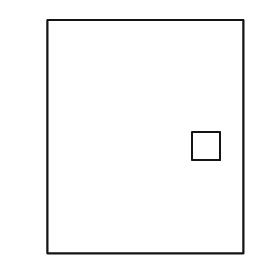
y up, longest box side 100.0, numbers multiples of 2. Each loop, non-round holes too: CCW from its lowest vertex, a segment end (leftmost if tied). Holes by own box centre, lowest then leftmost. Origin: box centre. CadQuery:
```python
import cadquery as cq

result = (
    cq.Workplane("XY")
    .moveTo(-42.0, -50.0)
    .lineTo(42.0, -50.0)
    .lineTo(42.0, 50.0)
    .lineTo(-42.0, 50.0)
    .close()
    .moveTo(20.0, -10.0)
    .lineTo(32.0, -10.0)
    .lineTo(32.0, 2.0)
    .lineTo(20.0, 2.0)
    .close()
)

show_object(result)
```